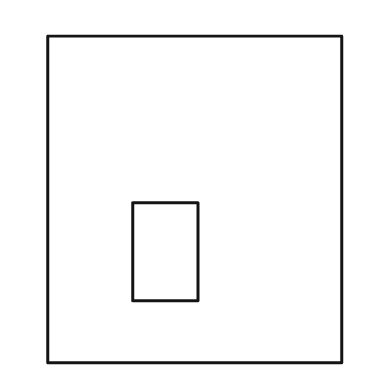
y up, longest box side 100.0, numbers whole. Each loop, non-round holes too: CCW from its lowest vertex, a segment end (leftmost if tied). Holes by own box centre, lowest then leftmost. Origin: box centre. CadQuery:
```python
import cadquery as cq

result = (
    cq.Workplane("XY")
    .moveTo(-45.0, -50.0)
    .lineTo(45.0, -50.0)
    .lineTo(45.0, 50.0)
    .lineTo(-45.0, 50.0)
    .close()
    .moveTo(-19.0, -31.0)
    .lineTo(1.0, -31.0)
    .lineTo(1.0, -1.0)
    .lineTo(-19.0, -1.0)
    .close()
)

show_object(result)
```